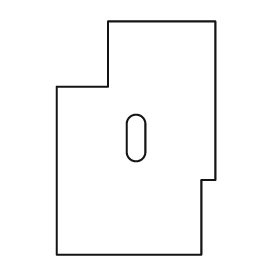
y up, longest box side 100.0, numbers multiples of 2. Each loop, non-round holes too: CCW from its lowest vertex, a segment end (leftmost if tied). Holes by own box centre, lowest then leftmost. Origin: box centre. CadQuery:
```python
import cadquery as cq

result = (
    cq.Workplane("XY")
    .moveTo(-34.0, -50.0)
    .lineTo(28.0, -50.0)
    .lineTo(28.0, -18.0)
    .lineTo(34.0, -18.0)
    .lineTo(34.0, 50.0)
    .lineTo(-12.0, 50.0)
    .lineTo(-12.0, 22.0)
    .lineTo(-34.0, 22.0)
    .close()
    .moveTo(-4.0, -6.0)
    .threePointArc((0.0, -10.0), (4.0, -6.0))
    .lineTo(4.0, 6.0)
    .threePointArc((0.0, 10.0), (-4.0, 6.0))
    .close()
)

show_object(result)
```